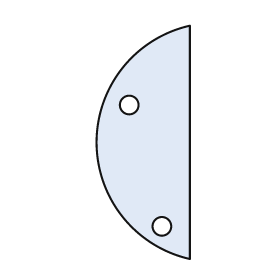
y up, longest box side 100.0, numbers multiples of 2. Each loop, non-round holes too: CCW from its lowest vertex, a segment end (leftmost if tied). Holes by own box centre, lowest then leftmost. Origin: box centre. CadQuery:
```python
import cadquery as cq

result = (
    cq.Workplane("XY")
    .moveTo(20.0, -50.0)
    .lineTo(20.0, 50.0)
    .threePointArc((-20.0, 0.0), (20.0, -50.0))
    .close()
    .moveTo(8.0, -36.0)
    .circle(4.0)
    .moveTo(-6.0, 16.0)
    .circle(4.0)
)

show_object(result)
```